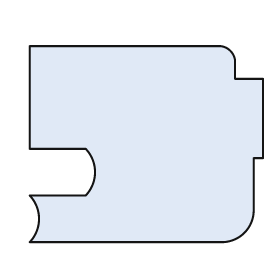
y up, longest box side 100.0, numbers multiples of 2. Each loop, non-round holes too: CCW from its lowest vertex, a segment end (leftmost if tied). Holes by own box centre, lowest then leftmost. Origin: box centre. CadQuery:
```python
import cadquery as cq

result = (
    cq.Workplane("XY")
    .moveTo(-50.0, -42.0)
    .lineTo(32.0, -42.0)
    .threePointArc((42.0, -38.0), (46.0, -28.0))
    .lineTo(46.0, -6.0)
    .lineTo(50.0, -6.0)
    .lineTo(50.0, 28.0)
    .lineTo(38.0, 28.0)
    .lineTo(38.0, 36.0)
    .threePointArc((36.0, 40.0), (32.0, 42.0))
    .lineTo(-50.0, 42.0)
    .lineTo(-50.0, -2.0)
    .lineTo(-26.0, -2.0)
    .threePointArc((-22.0, -12.0), (-26.0, -22.0))
    .lineTo(-50.0, -22.0)
    .threePointArc((-46.0, -32.0), (-50.0, -42.0))
    .close()
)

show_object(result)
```